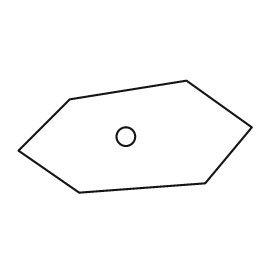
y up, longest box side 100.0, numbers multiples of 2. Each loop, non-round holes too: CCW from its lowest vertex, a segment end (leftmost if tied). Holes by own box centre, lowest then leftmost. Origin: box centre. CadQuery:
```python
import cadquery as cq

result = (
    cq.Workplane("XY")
    .moveTo(-24.0, -24.0)
    .lineTo(30.0, -20.0)
    .lineTo(50.0, 4.0)
    .lineTo(22.0, 24.0)
    .lineTo(-28.0, 16.0)
    .lineTo(-50.0, -6.0)
    .close()
    .moveTo(-4.0, 0.0)
    .circle(4.0)
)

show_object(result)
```